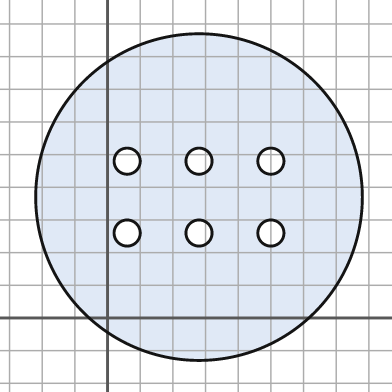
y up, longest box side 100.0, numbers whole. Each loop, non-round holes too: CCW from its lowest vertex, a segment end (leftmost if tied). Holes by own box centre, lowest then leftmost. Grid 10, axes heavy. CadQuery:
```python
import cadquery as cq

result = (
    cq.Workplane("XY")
    .moveTo(28.0, 37.0)
    .circle(50.0)
    .moveTo(6.0, 26.0)
    .circle(4.0)
    .moveTo(28.0, 26.0)
    .circle(4.0)
    .moveTo(50.0, 26.0)
    .circle(4.0)
    .moveTo(6.0, 48.0)
    .circle(4.0)
    .moveTo(28.0, 48.0)
    .circle(4.0)
    .moveTo(50.0, 48.0)
    .circle(4.0)
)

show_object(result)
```